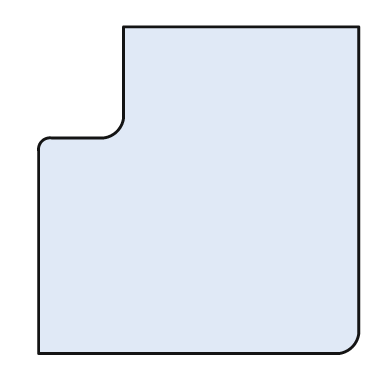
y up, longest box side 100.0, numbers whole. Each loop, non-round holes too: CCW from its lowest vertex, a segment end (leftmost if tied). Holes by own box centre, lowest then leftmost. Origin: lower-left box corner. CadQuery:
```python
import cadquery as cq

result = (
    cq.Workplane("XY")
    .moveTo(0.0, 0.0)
    .lineTo(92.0, 0.0)
    .threePointArc((96.0, 2.0), (98.0, 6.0))
    .lineTo(98.0, 100.0)
    .lineTo(26.0, 100.0)
    .lineTo(26.0, 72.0)
    .threePointArc((24.0, 68.0), (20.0, 66.0))
    .lineTo(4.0, 66.0)
    .threePointArc((1.0, 65.0), (0.0, 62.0))
    .close()
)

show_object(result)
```